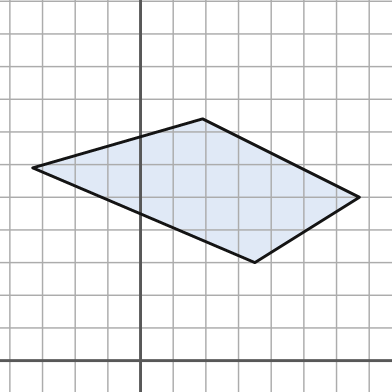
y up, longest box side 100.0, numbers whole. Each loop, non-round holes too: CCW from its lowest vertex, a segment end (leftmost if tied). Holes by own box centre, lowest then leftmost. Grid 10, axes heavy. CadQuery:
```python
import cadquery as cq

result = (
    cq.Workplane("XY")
    .moveTo(35.0, 30.0)
    .lineTo(67.0, 50.0)
    .lineTo(19.0, 74.0)
    .lineTo(-33.0, 59.0)
    .close()
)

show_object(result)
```